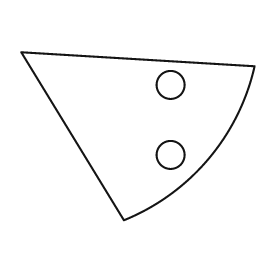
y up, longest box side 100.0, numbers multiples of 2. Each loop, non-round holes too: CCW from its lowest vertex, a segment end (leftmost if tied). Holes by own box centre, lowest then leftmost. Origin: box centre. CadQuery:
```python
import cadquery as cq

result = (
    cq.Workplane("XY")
    .moveTo(-6.0, -36.0)
    .threePointArc((30.0, -10.0), (50.0, 30.0))
    .lineTo(-50.0, 36.0)
    .close()
    .moveTo(14.0, -8.0)
    .circle(6.0)
    .moveTo(14.0, 22.0)
    .circle(6.0)
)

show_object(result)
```